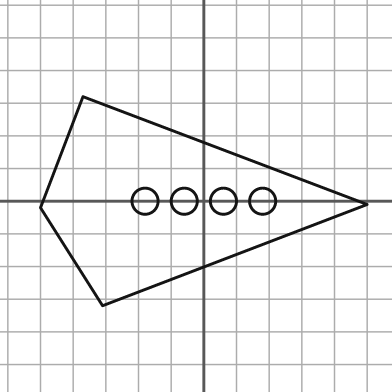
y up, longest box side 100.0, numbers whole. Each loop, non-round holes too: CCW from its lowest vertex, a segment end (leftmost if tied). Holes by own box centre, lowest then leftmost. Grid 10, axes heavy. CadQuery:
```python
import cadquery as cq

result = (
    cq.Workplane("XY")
    .moveTo(-31.0, -32.0)
    .lineTo(50.0, -1.0)
    .lineTo(-37.0, 32.0)
    .lineTo(-50.0, -2.0)
    .close()
    .moveTo(-18.0, 0.0)
    .circle(4.0)
    .moveTo(-6.0, 0.0)
    .circle(4.0)
    .moveTo(6.0, 0.0)
    .circle(4.0)
    .moveTo(18.0, 0.0)
    .circle(4.0)
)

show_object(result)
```